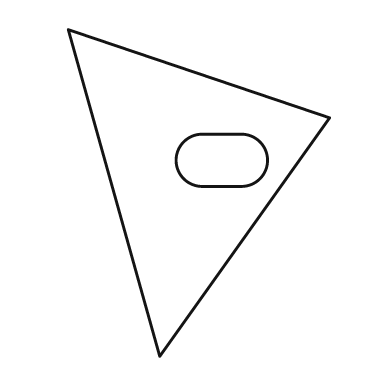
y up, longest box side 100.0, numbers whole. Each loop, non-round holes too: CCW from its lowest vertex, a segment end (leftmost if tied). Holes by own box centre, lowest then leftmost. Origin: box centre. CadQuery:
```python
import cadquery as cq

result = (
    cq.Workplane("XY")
    .moveTo(-12.0, -50.0)
    .lineTo(40.0, 23.0)
    .lineTo(-40.0, 50.0)
    .close()
    .moveTo(1.0, 2.0)
    .lineTo(13.0, 2.0)
    .threePointArc((21.0, 10.0), (13.0, 18.0))
    .lineTo(1.0, 18.0)
    .threePointArc((-7.0, 10.0), (1.0, 2.0))
    .close()
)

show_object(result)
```